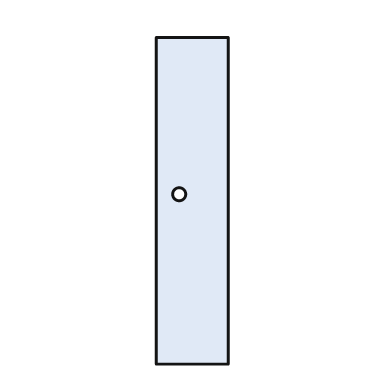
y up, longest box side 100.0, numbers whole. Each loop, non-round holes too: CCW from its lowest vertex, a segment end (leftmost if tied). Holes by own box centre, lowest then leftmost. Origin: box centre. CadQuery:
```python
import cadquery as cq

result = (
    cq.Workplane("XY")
    .moveTo(-11.0, -50.0)
    .lineTo(11.0, -50.0)
    .lineTo(11.0, 50.0)
    .lineTo(-11.0, 50.0)
    .close()
    .moveTo(-4.0, 2.0)
    .circle(2.0)
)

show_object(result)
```